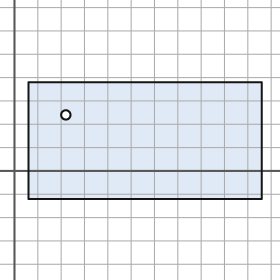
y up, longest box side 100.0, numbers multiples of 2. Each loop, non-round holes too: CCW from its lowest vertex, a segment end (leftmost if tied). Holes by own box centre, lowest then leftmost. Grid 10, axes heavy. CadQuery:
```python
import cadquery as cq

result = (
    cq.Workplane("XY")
    .moveTo(6.0, -12.0)
    .lineTo(106.0, -12.0)
    .lineTo(106.0, 38.0)
    .lineTo(6.0, 38.0)
    .close()
    .moveTo(22.0, 24.0)
    .circle(2.0)
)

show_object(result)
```